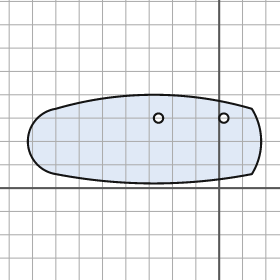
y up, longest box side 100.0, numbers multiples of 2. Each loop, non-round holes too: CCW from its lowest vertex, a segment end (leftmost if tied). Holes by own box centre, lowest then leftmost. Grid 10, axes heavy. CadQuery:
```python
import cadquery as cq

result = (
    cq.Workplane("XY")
    .moveTo(-70.0, 6.0)
    .threePointArc((-28.0, 2.0), (14.0, 6.0))
    .threePointArc((18.0, 20.0), (14.0, 34.0))
    .threePointArc((-28.0, 40.0), (-70.0, 34.0))
    .threePointArc((-82.0, 20.0), (-70.0, 6.0))
    .close()
    .moveTo(-26.0, 30.0)
    .circle(2.0)
    .moveTo(2.0, 30.0)
    .circle(2.0)
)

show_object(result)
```